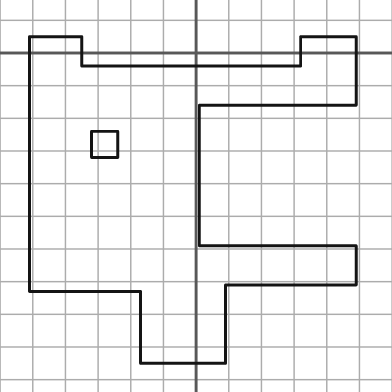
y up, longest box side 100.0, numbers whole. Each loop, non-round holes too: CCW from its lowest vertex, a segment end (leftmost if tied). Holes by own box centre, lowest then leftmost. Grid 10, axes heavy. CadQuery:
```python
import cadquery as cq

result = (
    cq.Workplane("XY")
    .moveTo(-17.0, -95.0)
    .lineTo(9.0, -95.0)
    .lineTo(9.0, -71.0)
    .lineTo(49.0, -71.0)
    .lineTo(49.0, -59.0)
    .lineTo(1.0, -59.0)
    .lineTo(1.0, -16.0)
    .lineTo(49.0, -16.0)
    .lineTo(49.0, 5.0)
    .lineTo(32.0, 5.0)
    .lineTo(32.0, -4.0)
    .lineTo(-35.0, -4.0)
    .lineTo(-35.0, 5.0)
    .lineTo(-51.0, 5.0)
    .lineTo(-51.0, -73.0)
    .lineTo(-17.0, -73.0)
    .close()
    .moveTo(-32.0, -32.0)
    .lineTo(-24.0, -32.0)
    .lineTo(-24.0, -24.0)
    .lineTo(-32.0, -24.0)
    .close()
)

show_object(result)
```